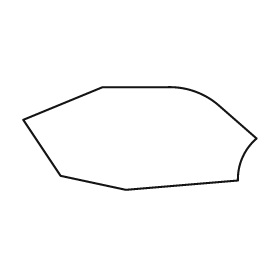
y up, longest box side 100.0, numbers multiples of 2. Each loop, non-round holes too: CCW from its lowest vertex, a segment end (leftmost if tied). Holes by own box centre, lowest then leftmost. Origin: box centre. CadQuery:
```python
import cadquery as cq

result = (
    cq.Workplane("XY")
    .moveTo(-6.0, -22.0)
    .lineTo(42.0, -18.0)
    .threePointArc((44.0, -8.0), (50.0, 0.0))
    .lineTo(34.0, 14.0)
    .threePointArc((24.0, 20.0), (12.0, 22.0))
    .lineTo(-16.0, 22.0)
    .lineTo(-50.0, 8.0)
    .lineTo(-34.0, -16.0)
    .close()
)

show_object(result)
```